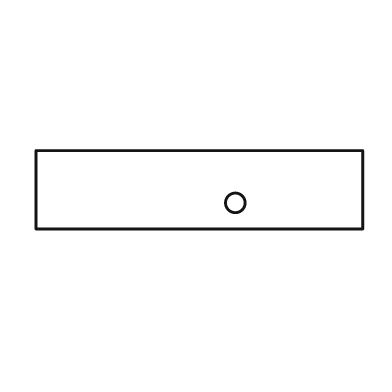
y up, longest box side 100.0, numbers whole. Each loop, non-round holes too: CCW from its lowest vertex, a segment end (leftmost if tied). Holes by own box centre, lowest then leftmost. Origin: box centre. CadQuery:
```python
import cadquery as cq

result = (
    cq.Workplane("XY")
    .moveTo(-50.0, -12.0)
    .lineTo(50.0, -12.0)
    .lineTo(50.0, 12.0)
    .lineTo(-50.0, 12.0)
    .close()
    .moveTo(11.0, -4.0)
    .circle(3.0)
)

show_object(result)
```